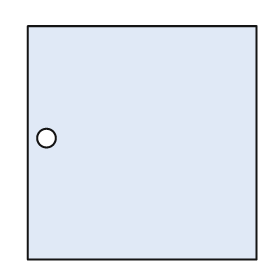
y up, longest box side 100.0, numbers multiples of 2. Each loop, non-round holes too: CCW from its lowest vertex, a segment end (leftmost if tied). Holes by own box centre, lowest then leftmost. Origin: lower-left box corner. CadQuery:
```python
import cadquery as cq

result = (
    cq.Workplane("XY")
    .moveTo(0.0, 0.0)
    .lineTo(98.0, 0.0)
    .lineTo(98.0, 100.0)
    .lineTo(0.0, 100.0)
    .close()
    .moveTo(8.0, 52.0)
    .circle(4.0)
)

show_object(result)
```